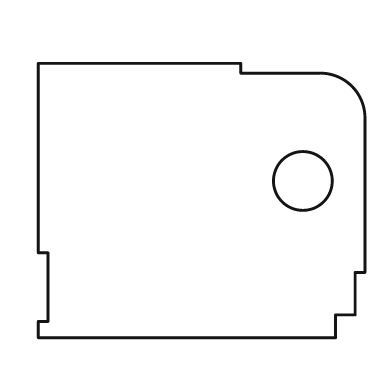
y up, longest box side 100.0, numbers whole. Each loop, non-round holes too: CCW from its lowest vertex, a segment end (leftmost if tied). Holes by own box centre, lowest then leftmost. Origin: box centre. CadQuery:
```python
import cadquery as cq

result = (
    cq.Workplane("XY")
    .moveTo(-50.0, -42.0)
    .lineTo(41.0, -42.0)
    .lineTo(41.0, -35.0)
    .lineTo(47.0, -35.0)
    .lineTo(47.0, -22.0)
    .lineTo(50.0, -22.0)
    .lineTo(50.0, 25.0)
    .threePointArc((46.0, 35.0), (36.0, 39.0))
    .lineTo(12.0, 39.0)
    .lineTo(12.0, 42.0)
    .lineTo(-50.0, 42.0)
    .lineTo(-50.0, -16.0)
    .lineTo(-47.0, -16.0)
    .lineTo(-47.0, -37.0)
    .lineTo(-50.0, -37.0)
    .close()
    .moveTo(31.0, 6.0)
    .circle(9.0)
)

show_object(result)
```